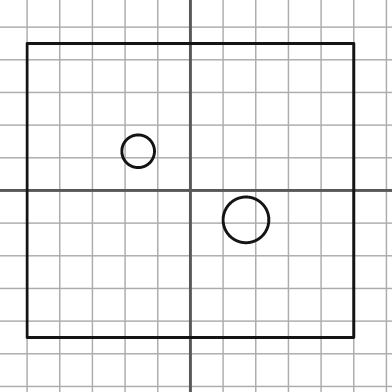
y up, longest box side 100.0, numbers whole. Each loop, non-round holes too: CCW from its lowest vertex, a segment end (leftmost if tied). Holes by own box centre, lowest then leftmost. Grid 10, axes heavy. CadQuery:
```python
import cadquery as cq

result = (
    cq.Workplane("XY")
    .moveTo(-50.0, -45.0)
    .lineTo(50.0, -45.0)
    .lineTo(50.0, 45.0)
    .lineTo(-50.0, 45.0)
    .close()
    .moveTo(17.0, -9.0)
    .circle(7.0)
    .moveTo(-16.0, 12.0)
    .circle(5.0)
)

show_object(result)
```